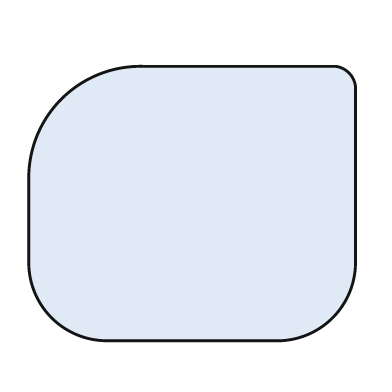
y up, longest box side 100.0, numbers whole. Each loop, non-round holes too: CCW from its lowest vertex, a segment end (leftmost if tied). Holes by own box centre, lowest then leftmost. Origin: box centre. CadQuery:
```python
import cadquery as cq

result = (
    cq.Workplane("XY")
    .moveTo(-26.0, -42.0)
    .lineTo(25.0, -42.0)
    .threePointArc((43.0, -35.0), (50.0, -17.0))
    .lineTo(50.0, 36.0)
    .threePointArc((48.0, 40.0), (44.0, 42.0))
    .lineTo(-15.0, 42.0)
    .threePointArc((-40.0, 32.0), (-50.0, 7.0))
    .lineTo(-50.0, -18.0)
    .threePointArc((-43.0, -35.0), (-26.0, -42.0))
    .close()
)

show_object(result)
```